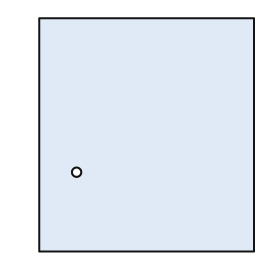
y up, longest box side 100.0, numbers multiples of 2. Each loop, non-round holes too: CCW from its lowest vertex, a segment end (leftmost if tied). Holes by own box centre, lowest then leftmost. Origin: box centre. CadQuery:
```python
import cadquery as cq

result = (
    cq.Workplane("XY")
    .moveTo(-46.0, -50.0)
    .lineTo(46.0, -50.0)
    .lineTo(46.0, 50.0)
    .lineTo(-46.0, 50.0)
    .close()
    .moveTo(-30.0, -16.0)
    .circle(2.0)
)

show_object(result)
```